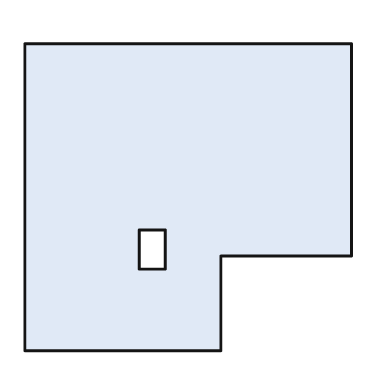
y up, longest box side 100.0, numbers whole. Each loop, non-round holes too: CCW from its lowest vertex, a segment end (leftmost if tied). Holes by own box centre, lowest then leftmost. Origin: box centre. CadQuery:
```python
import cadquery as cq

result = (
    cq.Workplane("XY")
    .moveTo(-50.0, -47.0)
    .lineTo(10.0, -47.0)
    .lineTo(10.0, -18.0)
    .lineTo(50.0, -18.0)
    .lineTo(50.0, 47.0)
    .lineTo(-50.0, 47.0)
    .close()
    .moveTo(-15.0, -22.0)
    .lineTo(-7.0, -22.0)
    .lineTo(-7.0, -10.0)
    .lineTo(-15.0, -10.0)
    .close()
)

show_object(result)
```